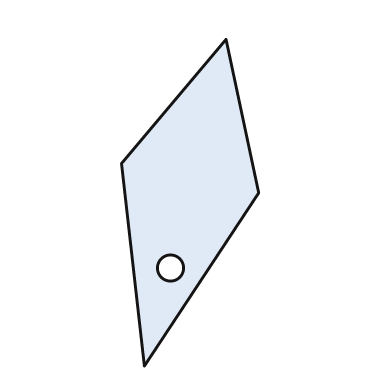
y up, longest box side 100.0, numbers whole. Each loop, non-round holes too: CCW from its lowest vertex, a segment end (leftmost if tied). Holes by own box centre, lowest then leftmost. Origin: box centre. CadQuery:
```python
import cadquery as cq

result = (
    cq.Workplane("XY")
    .moveTo(-14.0, -50.0)
    .lineTo(21.0, 3.0)
    .lineTo(11.0, 50.0)
    .lineTo(-21.0, 12.0)
    .close()
    .moveTo(-6.0, -20.0)
    .circle(4.0)
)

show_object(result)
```